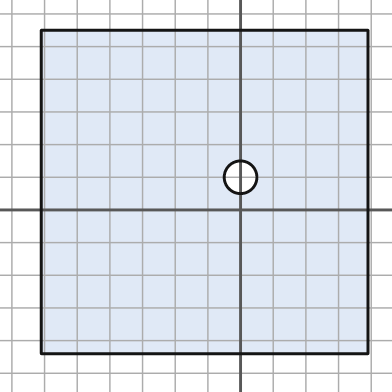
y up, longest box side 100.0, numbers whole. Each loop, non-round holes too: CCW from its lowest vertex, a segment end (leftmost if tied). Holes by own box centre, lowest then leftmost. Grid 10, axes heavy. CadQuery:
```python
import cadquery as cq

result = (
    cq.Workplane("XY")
    .moveTo(-61.0, -44.0)
    .lineTo(39.0, -44.0)
    .lineTo(39.0, 55.0)
    .lineTo(-61.0, 55.0)
    .close()
    .moveTo(0.0, 10.0)
    .circle(5.0)
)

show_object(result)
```